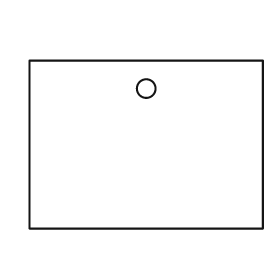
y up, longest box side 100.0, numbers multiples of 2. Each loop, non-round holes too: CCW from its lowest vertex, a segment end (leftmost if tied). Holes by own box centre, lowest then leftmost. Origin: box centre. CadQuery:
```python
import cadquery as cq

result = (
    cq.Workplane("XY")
    .moveTo(-50.0, -36.0)
    .lineTo(50.0, -36.0)
    .lineTo(50.0, 36.0)
    .lineTo(-50.0, 36.0)
    .close()
    .moveTo(0.0, 24.0)
    .circle(4.0)
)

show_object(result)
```